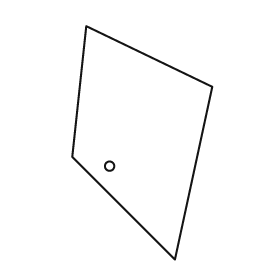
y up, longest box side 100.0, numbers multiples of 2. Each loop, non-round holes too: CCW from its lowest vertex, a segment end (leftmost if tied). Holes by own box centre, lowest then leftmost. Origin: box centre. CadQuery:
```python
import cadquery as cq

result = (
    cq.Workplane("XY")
    .moveTo(14.0, -50.0)
    .lineTo(30.0, 24.0)
    .lineTo(-24.0, 50.0)
    .lineTo(-30.0, -6.0)
    .close()
    .moveTo(-14.0, -10.0)
    .circle(2.0)
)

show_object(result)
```